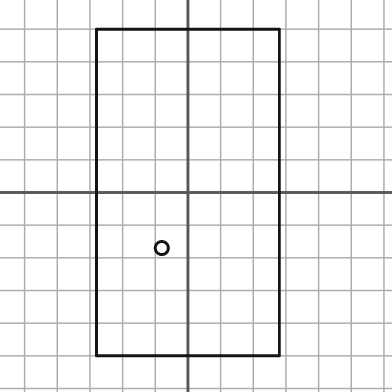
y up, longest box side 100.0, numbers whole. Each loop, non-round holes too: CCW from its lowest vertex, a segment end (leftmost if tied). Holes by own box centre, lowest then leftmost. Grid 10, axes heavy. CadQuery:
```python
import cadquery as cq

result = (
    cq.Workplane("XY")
    .moveTo(-28.0, -50.0)
    .lineTo(28.0, -50.0)
    .lineTo(28.0, 50.0)
    .lineTo(-28.0, 50.0)
    .close()
    .moveTo(-8.0, -17.0)
    .circle(2.0)
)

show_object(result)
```